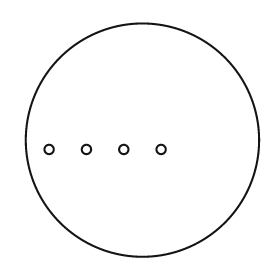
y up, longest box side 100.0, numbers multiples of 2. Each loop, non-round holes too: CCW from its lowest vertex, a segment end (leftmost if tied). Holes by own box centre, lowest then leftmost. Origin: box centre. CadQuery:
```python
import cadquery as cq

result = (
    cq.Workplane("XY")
    .moveTo(0.0, 0.0)
    .circle(50.0)
    .moveTo(-40.0, -4.0)
    .circle(2.0)
    .moveTo(-24.0, -4.0)
    .circle(2.0)
    .moveTo(-8.0, -4.0)
    .circle(2.0)
    .moveTo(8.0, -4.0)
    .circle(2.0)
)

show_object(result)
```